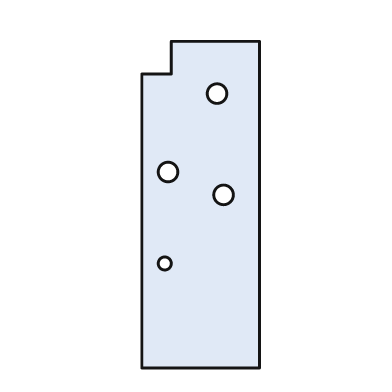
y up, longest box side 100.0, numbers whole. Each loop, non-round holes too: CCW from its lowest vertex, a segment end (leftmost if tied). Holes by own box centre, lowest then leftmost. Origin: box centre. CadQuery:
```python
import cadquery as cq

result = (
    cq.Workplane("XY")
    .moveTo(-18.0, -50.0)
    .lineTo(18.0, -50.0)
    .lineTo(18.0, 50.0)
    .lineTo(-9.0, 50.0)
    .lineTo(-9.0, 40.0)
    .lineTo(-18.0, 40.0)
    .close()
    .moveTo(-11.0, -18.0)
    .circle(2.0)
    .moveTo(7.0, 3.0)
    .circle(3.0)
    .moveTo(-10.0, 10.0)
    .circle(3.0)
    .moveTo(5.0, 34.0)
    .circle(3.0)
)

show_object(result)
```